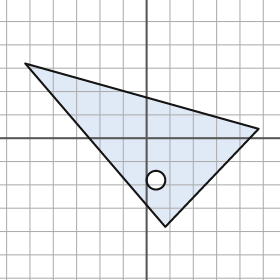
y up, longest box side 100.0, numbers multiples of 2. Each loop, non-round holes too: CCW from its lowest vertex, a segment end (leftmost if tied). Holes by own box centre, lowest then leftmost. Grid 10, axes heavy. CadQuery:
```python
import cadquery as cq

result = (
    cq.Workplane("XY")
    .moveTo(8.0, -38.0)
    .lineTo(48.0, 4.0)
    .lineTo(-52.0, 32.0)
    .close()
    .moveTo(4.0, -18.0)
    .circle(4.0)
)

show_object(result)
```